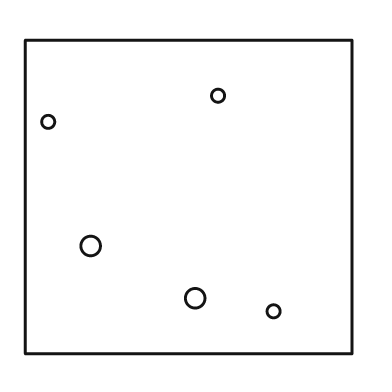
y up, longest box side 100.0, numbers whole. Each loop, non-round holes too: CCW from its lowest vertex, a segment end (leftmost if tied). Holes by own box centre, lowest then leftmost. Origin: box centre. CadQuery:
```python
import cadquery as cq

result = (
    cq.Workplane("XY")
    .moveTo(-50.0, -48.0)
    .lineTo(50.0, -48.0)
    .lineTo(50.0, 48.0)
    .lineTo(-50.0, 48.0)
    .close()
    .moveTo(26.0, -35.0)
    .circle(2.0)
    .moveTo(2.0, -31.0)
    .circle(3.0)
    .moveTo(-30.0, -15.0)
    .circle(3.0)
    .moveTo(-43.0, 23.0)
    .circle(2.0)
    .moveTo(9.0, 31.0)
    .circle(2.0)
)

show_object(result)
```